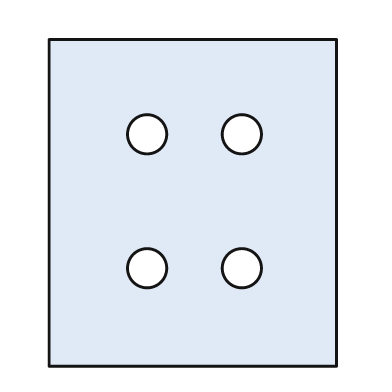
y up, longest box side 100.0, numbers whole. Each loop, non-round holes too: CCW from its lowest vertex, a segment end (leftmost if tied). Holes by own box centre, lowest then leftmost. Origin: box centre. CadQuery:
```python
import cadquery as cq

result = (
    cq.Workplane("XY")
    .moveTo(-44.0, -50.0)
    .lineTo(44.0, -50.0)
    .lineTo(44.0, 50.0)
    .lineTo(-44.0, 50.0)
    .close()
    .moveTo(-14.0, -20.0)
    .circle(6.0)
    .moveTo(15.0, -20.0)
    .circle(6.0)
    .moveTo(-14.0, 21.0)
    .circle(6.0)
    .moveTo(15.0, 21.0)
    .circle(6.0)
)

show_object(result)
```